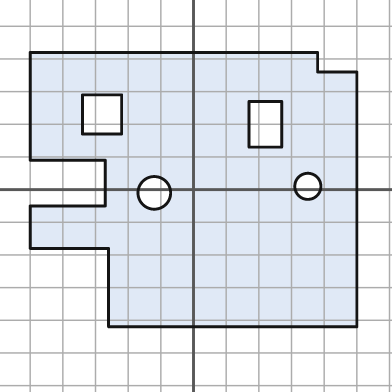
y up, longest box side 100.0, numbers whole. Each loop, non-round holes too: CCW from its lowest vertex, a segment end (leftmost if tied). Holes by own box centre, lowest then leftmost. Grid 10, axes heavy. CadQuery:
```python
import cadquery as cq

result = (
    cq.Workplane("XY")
    .moveTo(-26.0, -42.0)
    .lineTo(50.0, -42.0)
    .lineTo(50.0, 36.0)
    .lineTo(38.0, 36.0)
    .lineTo(38.0, 42.0)
    .lineTo(-50.0, 42.0)
    .lineTo(-50.0, 9.0)
    .lineTo(-27.0, 9.0)
    .lineTo(-27.0, -5.0)
    .lineTo(-50.0, -5.0)
    .lineTo(-50.0, -18.0)
    .lineTo(-26.0, -18.0)
    .close()
    .moveTo(-12.0, -1.0)
    .circle(5.0)
    .moveTo(35.0, 1.0)
    .circle(4.0)
    .moveTo(17.0, 13.0)
    .lineTo(27.0, 13.0)
    .lineTo(27.0, 27.0)
    .lineTo(17.0, 27.0)
    .close()
    .moveTo(-34.0, 17.0)
    .lineTo(-22.0, 17.0)
    .lineTo(-22.0, 29.0)
    .lineTo(-34.0, 29.0)
    .close()
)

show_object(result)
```